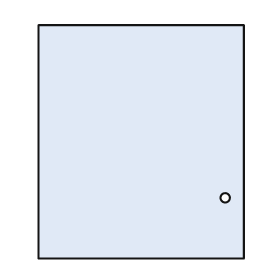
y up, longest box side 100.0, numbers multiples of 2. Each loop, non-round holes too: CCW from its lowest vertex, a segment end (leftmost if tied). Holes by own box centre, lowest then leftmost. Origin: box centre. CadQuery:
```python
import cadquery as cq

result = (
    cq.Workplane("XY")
    .moveTo(-44.0, -50.0)
    .lineTo(44.0, -50.0)
    .lineTo(44.0, 50.0)
    .lineTo(-44.0, 50.0)
    .close()
    .moveTo(36.0, -24.0)
    .circle(2.0)
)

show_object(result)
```